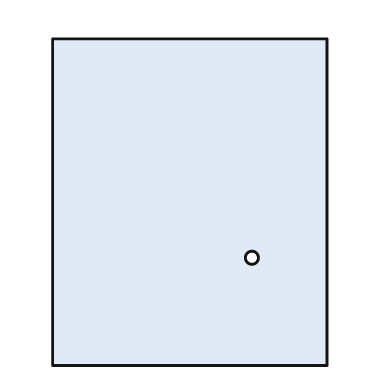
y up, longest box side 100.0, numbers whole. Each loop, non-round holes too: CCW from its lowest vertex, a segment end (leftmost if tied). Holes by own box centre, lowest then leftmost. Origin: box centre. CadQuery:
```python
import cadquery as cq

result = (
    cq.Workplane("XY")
    .moveTo(-42.0, -50.0)
    .lineTo(42.0, -50.0)
    .lineTo(42.0, 50.0)
    .lineTo(-42.0, 50.0)
    .close()
    .moveTo(19.0, -17.0)
    .circle(2.0)
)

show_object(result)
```